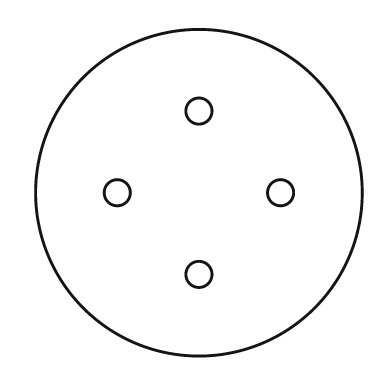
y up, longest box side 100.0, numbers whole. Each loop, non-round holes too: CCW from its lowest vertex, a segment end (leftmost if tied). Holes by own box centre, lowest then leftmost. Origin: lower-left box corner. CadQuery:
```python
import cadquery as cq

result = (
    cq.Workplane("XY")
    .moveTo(50.0, 50.0)
    .circle(50.0)
    .moveTo(50.0, 25.0)
    .circle(4.0)
    .moveTo(25.0, 50.0)
    .circle(4.0)
    .moveTo(75.0, 50.0)
    .circle(4.0)
    .moveTo(50.0, 75.0)
    .circle(4.0)
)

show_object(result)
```